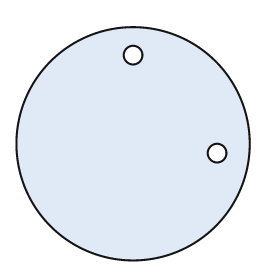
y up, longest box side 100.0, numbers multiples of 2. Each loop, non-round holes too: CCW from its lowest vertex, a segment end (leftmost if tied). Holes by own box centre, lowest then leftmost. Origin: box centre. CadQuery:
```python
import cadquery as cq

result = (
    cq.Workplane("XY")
    .moveTo(0.0, 0.0)
    .circle(50.0)
    .moveTo(36.0, -4.0)
    .circle(4.0)
    .moveTo(0.0, 38.0)
    .circle(4.0)
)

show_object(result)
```